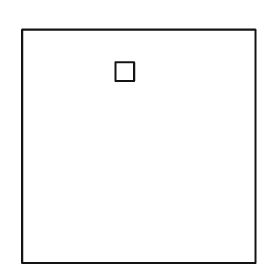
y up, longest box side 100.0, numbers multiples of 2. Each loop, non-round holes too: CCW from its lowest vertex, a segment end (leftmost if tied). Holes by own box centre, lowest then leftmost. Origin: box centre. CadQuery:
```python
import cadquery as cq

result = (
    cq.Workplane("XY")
    .moveTo(-50.0, -50.0)
    .lineTo(50.0, -50.0)
    .lineTo(50.0, 50.0)
    .lineTo(-50.0, 50.0)
    .close()
    .moveTo(-10.0, 28.0)
    .lineTo(-2.0, 28.0)
    .lineTo(-2.0, 36.0)
    .lineTo(-10.0, 36.0)
    .close()
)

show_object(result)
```